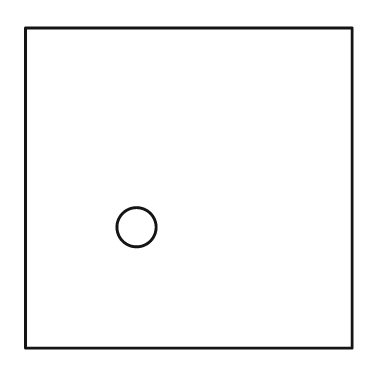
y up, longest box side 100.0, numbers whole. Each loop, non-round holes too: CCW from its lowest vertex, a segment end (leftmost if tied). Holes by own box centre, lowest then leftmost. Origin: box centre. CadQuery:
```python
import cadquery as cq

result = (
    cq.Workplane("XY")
    .moveTo(-50.0, -49.0)
    .lineTo(50.0, -49.0)
    .lineTo(50.0, 49.0)
    .lineTo(-50.0, 49.0)
    .close()
    .moveTo(-16.0, -12.0)
    .circle(6.0)
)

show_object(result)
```